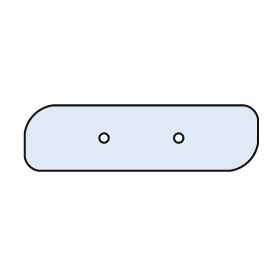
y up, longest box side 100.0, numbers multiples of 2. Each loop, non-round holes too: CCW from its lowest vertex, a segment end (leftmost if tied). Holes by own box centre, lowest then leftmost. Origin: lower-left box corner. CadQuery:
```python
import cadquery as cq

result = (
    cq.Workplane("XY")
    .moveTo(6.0, 0.0)
    .lineTo(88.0, 0.0)
    .threePointArc((96.0, 4.0), (100.0, 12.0))
    .lineTo(100.0, 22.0)
    .threePointArc((98.0, 26.0), (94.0, 28.0))
    .lineTo(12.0, 28.0)
    .threePointArc((4.0, 24.0), (0.0, 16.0))
    .lineTo(0.0, 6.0)
    .threePointArc((2.0, 2.0), (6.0, 0.0))
    .close()
    .moveTo(34.0, 14.0)
    .circle(2.0)
    .moveTo(66.0, 14.0)
    .circle(2.0)
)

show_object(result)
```